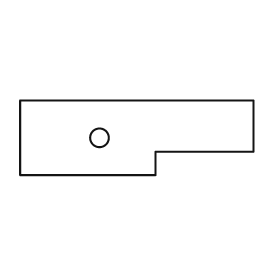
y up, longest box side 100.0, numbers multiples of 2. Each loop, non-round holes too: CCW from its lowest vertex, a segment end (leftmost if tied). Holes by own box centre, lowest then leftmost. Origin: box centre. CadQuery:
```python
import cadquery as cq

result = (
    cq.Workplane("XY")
    .moveTo(-50.0, -16.0)
    .lineTo(8.0, -16.0)
    .lineTo(8.0, -6.0)
    .lineTo(50.0, -6.0)
    .lineTo(50.0, 16.0)
    .lineTo(-50.0, 16.0)
    .close()
    .moveTo(-16.0, 0.0)
    .circle(4.0)
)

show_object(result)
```